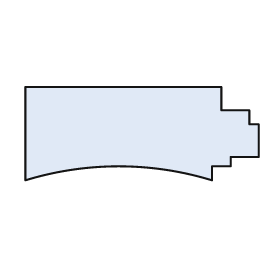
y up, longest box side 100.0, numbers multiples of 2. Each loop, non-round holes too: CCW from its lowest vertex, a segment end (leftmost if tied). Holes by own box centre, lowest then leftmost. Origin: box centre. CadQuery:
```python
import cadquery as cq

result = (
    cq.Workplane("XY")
    .moveTo(-50.0, -20.0)
    .threePointArc((-10.0, -14.0), (30.0, -20.0))
    .lineTo(30.0, -14.0)
    .lineTo(38.0, -14.0)
    .lineTo(38.0, -10.0)
    .lineTo(50.0, -10.0)
    .lineTo(50.0, 4.0)
    .lineTo(46.0, 4.0)
    .lineTo(46.0, 10.0)
    .lineTo(34.0, 10.0)
    .lineTo(34.0, 20.0)
    .lineTo(-50.0, 20.0)
    .close()
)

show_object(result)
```